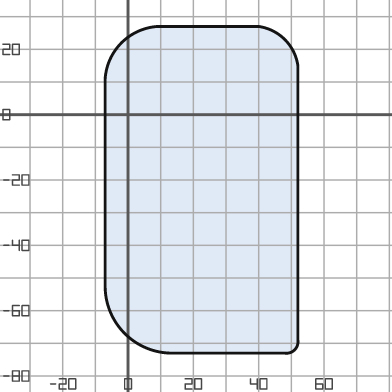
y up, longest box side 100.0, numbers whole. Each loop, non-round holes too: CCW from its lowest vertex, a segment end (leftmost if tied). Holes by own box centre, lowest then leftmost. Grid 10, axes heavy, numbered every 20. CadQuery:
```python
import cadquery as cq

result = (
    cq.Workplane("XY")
    .moveTo(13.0, -73.0)
    .lineTo(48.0, -73.0)
    .threePointArc((51.0, -72.0), (52.0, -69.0))
    .lineTo(52.0, 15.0)
    .threePointArc((48.0, 23.0), (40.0, 27.0))
    .lineTo(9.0, 27.0)
    .threePointArc((-2.0, 22.0), (-7.0, 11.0))
    .lineTo(-7.0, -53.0)
    .threePointArc((-1.0, -67.0), (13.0, -73.0))
    .close()
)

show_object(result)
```